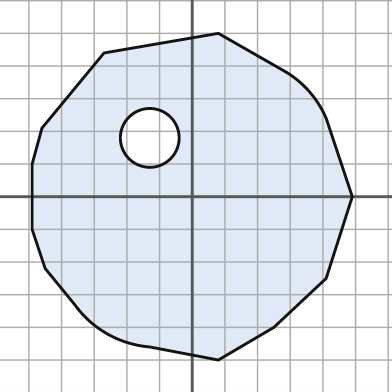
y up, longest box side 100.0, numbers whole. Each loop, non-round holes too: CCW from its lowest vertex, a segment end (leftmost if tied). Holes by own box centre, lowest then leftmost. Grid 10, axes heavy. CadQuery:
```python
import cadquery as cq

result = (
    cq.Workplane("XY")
    .moveTo(8.0, -50.0)
    .lineTo(25.0, -40.0)
    .lineTo(41.0, -25.0)
    .lineTo(49.0, 0.0)
    .lineTo(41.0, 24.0)
    .threePointArc((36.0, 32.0), (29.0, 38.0))
    .lineTo(8.0, 50.0)
    .lineTo(-27.0, 44.0)
    .lineTo(-46.0, 21.0)
    .lineTo(-49.0, 10.0)
    .lineTo(-49.0, -10.0)
    .lineTo(-45.0, -22.0)
    .lineTo(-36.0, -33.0)
    .threePointArc((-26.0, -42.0), (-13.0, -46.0))
    .close()
    .moveTo(-13.0, 18.0)
    .circle(9.0)
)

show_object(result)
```